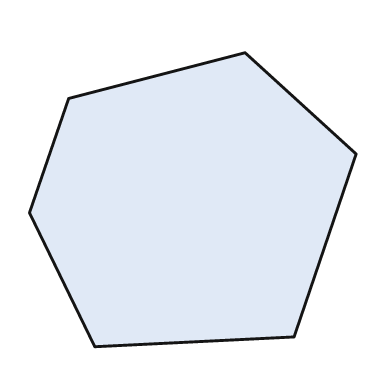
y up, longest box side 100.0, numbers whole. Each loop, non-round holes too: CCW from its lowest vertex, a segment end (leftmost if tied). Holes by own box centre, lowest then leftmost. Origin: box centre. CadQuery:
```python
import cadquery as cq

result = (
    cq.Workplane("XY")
    .moveTo(-30.0, -45.0)
    .lineTo(31.0, -42.0)
    .lineTo(50.0, 14.0)
    .lineTo(16.0, 45.0)
    .lineTo(-38.0, 31.0)
    .lineTo(-50.0, -4.0)
    .close()
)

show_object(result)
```